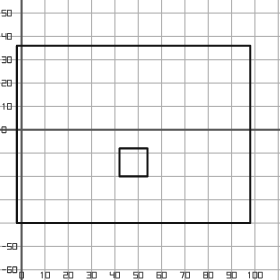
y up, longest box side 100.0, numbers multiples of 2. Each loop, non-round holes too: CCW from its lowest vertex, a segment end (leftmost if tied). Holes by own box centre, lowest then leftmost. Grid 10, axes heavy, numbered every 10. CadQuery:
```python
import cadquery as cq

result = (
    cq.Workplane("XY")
    .moveTo(-2.0, -40.0)
    .lineTo(98.0, -40.0)
    .lineTo(98.0, 36.0)
    .lineTo(-2.0, 36.0)
    .close()
    .moveTo(42.0, -20.0)
    .lineTo(54.0, -20.0)
    .lineTo(54.0, -8.0)
    .lineTo(42.0, -8.0)
    .close()
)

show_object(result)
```